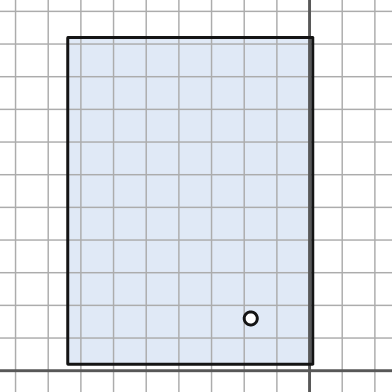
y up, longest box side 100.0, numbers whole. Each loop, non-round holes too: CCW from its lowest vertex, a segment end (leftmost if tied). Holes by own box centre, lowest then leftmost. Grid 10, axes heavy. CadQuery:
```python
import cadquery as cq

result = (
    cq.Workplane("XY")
    .moveTo(-74.0, 2.0)
    .lineTo(1.0, 2.0)
    .lineTo(1.0, 102.0)
    .lineTo(-74.0, 102.0)
    .close()
    .moveTo(-18.0, 16.0)
    .circle(2.0)
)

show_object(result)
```